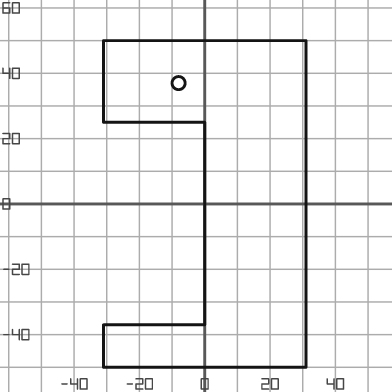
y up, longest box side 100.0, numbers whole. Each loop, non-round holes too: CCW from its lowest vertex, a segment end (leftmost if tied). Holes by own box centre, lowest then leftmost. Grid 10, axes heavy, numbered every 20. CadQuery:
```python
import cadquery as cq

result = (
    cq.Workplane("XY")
    .moveTo(-31.0, -50.0)
    .lineTo(31.0, -50.0)
    .lineTo(31.0, 50.0)
    .lineTo(-31.0, 50.0)
    .lineTo(-31.0, 25.0)
    .lineTo(0.0, 25.0)
    .lineTo(0.0, -37.0)
    .lineTo(-31.0, -37.0)
    .close()
    .moveTo(-8.0, 37.0)
    .circle(2.0)
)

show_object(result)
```